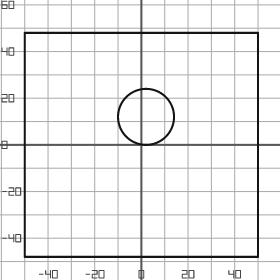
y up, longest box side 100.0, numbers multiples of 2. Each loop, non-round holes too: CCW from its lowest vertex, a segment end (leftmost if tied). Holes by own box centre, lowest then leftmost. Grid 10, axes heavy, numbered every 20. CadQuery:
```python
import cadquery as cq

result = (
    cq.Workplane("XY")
    .moveTo(-50.0, -48.0)
    .lineTo(50.0, -48.0)
    .lineTo(50.0, 48.0)
    .lineTo(-50.0, 48.0)
    .close()
    .moveTo(2.0, 12.0)
    .circle(12.0)
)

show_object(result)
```